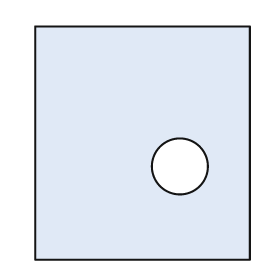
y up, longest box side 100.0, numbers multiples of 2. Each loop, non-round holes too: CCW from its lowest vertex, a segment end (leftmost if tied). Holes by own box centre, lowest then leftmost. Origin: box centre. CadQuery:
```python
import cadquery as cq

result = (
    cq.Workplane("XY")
    .moveTo(-46.0, -50.0)
    .lineTo(46.0, -50.0)
    .lineTo(46.0, 50.0)
    .lineTo(-46.0, 50.0)
    .close()
    .moveTo(16.0, -10.0)
    .circle(12.0)
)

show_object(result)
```